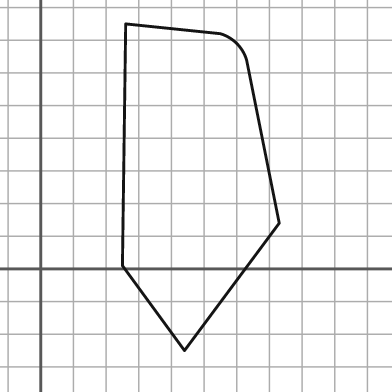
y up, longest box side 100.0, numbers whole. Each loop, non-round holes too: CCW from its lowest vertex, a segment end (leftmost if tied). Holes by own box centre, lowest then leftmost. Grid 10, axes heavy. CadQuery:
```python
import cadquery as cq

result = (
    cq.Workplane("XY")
    .moveTo(44.0, -25.0)
    .lineTo(73.0, 14.0)
    .lineTo(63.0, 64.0)
    .threePointArc((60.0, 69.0), (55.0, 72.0))
    .lineTo(26.0, 75.0)
    .lineTo(25.0, 1.0)
    .close()
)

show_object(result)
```